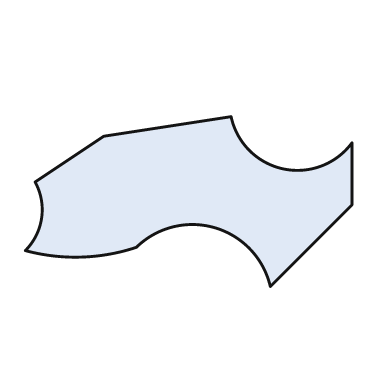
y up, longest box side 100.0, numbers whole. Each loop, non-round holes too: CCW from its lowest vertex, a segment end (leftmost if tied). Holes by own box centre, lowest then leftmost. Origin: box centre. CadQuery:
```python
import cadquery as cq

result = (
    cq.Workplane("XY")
    .moveTo(25.0, -26.0)
    .lineTo(50.0, -1.0)
    .lineTo(50.0, 18.0)
    .threePointArc((29.0, 10.0), (13.0, 26.0))
    .lineTo(-26.0, 20.0)
    .lineTo(-47.0, 6.0)
    .threePointArc((-45.0, -5.0), (-50.0, -15.0))
    .threePointArc((-33.0, -17.0), (-16.0, -14.0))
    .threePointArc((8.0, -8.0), (25.0, -26.0))
    .close()
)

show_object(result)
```